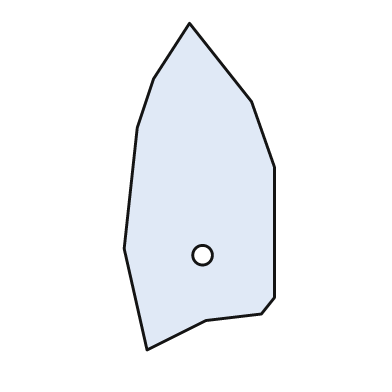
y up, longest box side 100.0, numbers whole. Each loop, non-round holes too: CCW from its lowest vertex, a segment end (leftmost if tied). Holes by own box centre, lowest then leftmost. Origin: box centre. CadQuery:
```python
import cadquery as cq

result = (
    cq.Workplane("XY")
    .moveTo(-16.0, -50.0)
    .lineTo(2.0, -41.0)
    .lineTo(19.0, -39.0)
    .lineTo(23.0, -34.0)
    .lineTo(23.0, 6.0)
    .lineTo(16.0, 26.0)
    .lineTo(-3.0, 50.0)
    .lineTo(-14.0, 33.0)
    .lineTo(-19.0, 18.0)
    .lineTo(-23.0, -19.0)
    .close()
    .moveTo(1.0, -21.0)
    .circle(3.0)
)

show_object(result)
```